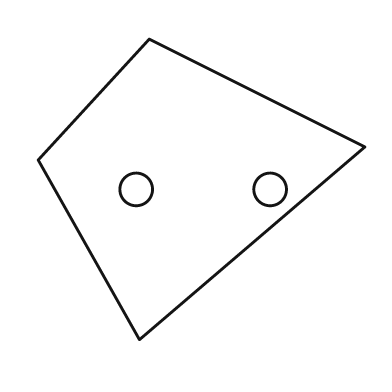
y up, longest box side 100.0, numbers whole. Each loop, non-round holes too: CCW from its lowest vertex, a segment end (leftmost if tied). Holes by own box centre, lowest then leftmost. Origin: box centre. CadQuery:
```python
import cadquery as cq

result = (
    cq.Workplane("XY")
    .moveTo(-19.0, -46.0)
    .lineTo(50.0, 13.0)
    .lineTo(-16.0, 46.0)
    .lineTo(-50.0, 9.0)
    .close()
    .moveTo(-20.0, 0.0)
    .circle(5.0)
    .moveTo(21.0, 0.0)
    .circle(5.0)
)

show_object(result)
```